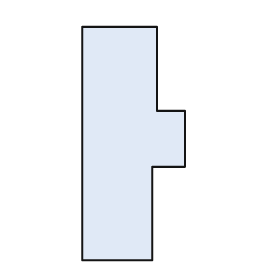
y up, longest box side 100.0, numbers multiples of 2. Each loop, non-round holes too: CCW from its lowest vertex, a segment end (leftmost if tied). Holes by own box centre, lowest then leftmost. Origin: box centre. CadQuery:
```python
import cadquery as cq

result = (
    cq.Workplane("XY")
    .moveTo(-22.0, -50.0)
    .lineTo(8.0, -50.0)
    .lineTo(8.0, -10.0)
    .lineTo(22.0, -10.0)
    .lineTo(22.0, 14.0)
    .lineTo(10.0, 14.0)
    .lineTo(10.0, 50.0)
    .lineTo(-22.0, 50.0)
    .close()
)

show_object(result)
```